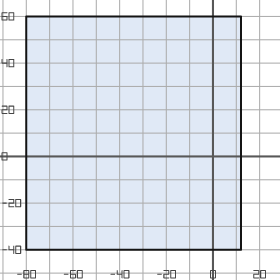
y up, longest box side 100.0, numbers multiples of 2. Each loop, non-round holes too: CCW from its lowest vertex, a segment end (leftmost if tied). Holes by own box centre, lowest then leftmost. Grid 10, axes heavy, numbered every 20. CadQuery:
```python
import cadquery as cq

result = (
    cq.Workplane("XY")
    .moveTo(-80.0, -40.0)
    .lineTo(12.0, -40.0)
    .lineTo(12.0, 60.0)
    .lineTo(-80.0, 60.0)
    .close()
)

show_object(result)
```